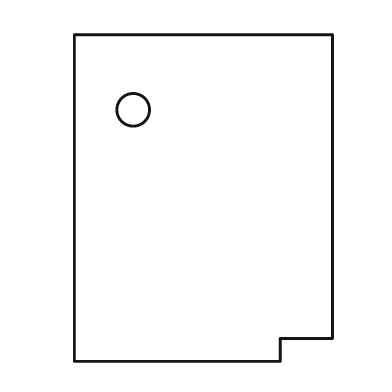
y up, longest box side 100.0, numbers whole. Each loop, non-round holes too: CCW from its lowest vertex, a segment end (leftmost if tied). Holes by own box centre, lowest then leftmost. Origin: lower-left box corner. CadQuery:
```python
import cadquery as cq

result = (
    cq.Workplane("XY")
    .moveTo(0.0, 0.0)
    .lineTo(63.0, 0.0)
    .lineTo(63.0, 7.0)
    .lineTo(79.0, 7.0)
    .lineTo(79.0, 100.0)
    .lineTo(0.0, 100.0)
    .close()
    .moveTo(18.0, 77.0)
    .circle(5.0)
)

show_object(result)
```